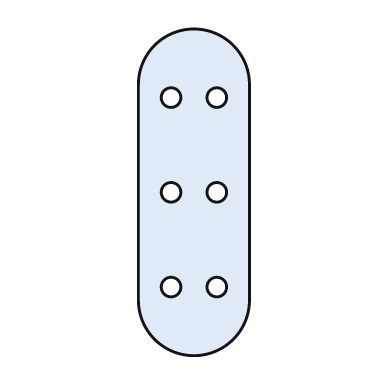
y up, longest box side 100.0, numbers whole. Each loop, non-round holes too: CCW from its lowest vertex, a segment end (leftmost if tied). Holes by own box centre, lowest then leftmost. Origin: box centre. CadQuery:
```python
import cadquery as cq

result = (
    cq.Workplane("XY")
    .moveTo(-17.0, -33.0)
    .threePointArc((0.0, -50.0), (17.0, -33.0))
    .lineTo(17.0, 33.0)
    .threePointArc((0.0, 50.0), (-17.0, 33.0))
    .close()
    .moveTo(-7.0, -29.0)
    .circle(3.0)
    .moveTo(7.0, -29.0)
    .circle(3.0)
    .moveTo(-7.0, 0.0)
    .circle(3.0)
    .moveTo(7.0, 0.0)
    .circle(3.0)
    .moveTo(-7.0, 29.0)
    .circle(3.0)
    .moveTo(7.0, 29.0)
    .circle(3.0)
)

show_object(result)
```